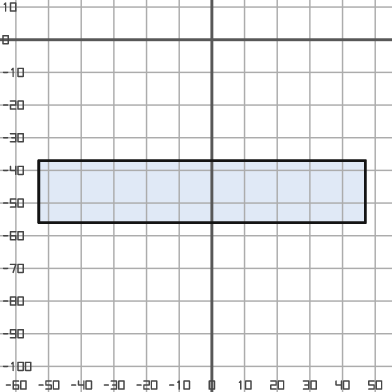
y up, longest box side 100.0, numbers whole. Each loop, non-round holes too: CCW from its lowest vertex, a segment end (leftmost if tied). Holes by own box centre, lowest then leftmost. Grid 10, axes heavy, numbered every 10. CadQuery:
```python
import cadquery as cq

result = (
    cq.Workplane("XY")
    .moveTo(-53.0, -56.0)
    .lineTo(47.0, -56.0)
    .lineTo(47.0, -37.0)
    .lineTo(-53.0, -37.0)
    .close()
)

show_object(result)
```